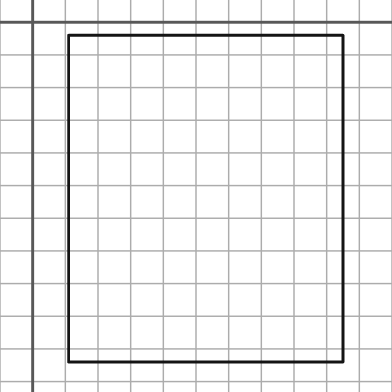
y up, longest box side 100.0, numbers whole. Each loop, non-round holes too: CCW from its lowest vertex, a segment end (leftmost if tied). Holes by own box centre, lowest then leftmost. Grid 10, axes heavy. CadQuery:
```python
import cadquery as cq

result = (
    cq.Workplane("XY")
    .moveTo(11.0, -104.0)
    .lineTo(95.0, -104.0)
    .lineTo(95.0, -4.0)
    .lineTo(11.0, -4.0)
    .close()
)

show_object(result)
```